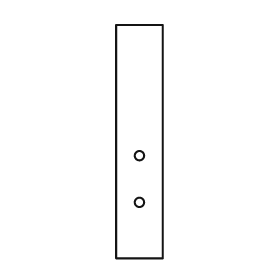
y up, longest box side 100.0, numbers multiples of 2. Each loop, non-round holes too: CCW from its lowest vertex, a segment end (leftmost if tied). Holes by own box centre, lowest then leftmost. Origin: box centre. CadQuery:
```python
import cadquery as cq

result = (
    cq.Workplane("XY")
    .moveTo(-10.0, -50.0)
    .lineTo(10.0, -50.0)
    .lineTo(10.0, 50.0)
    .lineTo(-10.0, 50.0)
    .close()
    .moveTo(0.0, -26.0)
    .circle(2.0)
    .moveTo(0.0, -6.0)
    .circle(2.0)
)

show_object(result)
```